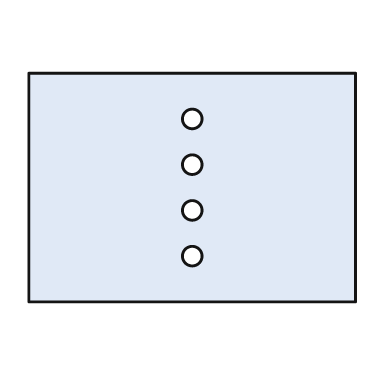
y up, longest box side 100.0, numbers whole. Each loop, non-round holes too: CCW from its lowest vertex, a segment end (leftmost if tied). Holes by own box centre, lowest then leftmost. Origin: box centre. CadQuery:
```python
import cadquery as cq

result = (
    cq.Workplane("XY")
    .moveTo(-50.0, -35.0)
    .lineTo(50.0, -35.0)
    .lineTo(50.0, 35.0)
    .lineTo(-50.0, 35.0)
    .close()
    .moveTo(0.0, -21.0)
    .circle(3.0)
    .moveTo(0.0, -7.0)
    .circle(3.0)
    .moveTo(0.0, 7.0)
    .circle(3.0)
    .moveTo(0.0, 21.0)
    .circle(3.0)
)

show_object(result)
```